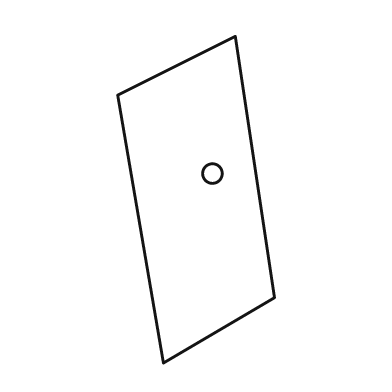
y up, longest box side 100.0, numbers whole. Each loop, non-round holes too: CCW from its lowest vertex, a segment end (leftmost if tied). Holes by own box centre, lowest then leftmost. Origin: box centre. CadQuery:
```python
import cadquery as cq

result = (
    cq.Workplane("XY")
    .moveTo(-10.0, -50.0)
    .lineTo(24.0, -30.0)
    .lineTo(12.0, 50.0)
    .lineTo(-24.0, 32.0)
    .close()
    .moveTo(5.0, 8.0)
    .circle(3.0)
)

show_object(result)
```